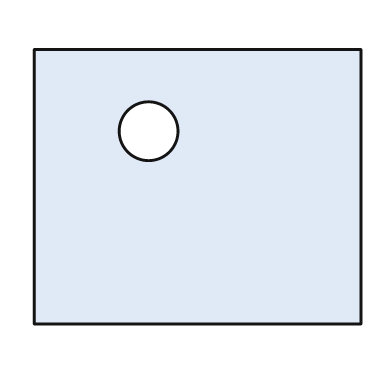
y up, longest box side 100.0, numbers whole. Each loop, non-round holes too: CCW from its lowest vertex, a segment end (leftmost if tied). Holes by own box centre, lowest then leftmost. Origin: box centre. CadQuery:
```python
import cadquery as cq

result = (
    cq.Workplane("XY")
    .moveTo(-50.0, -42.0)
    .lineTo(50.0, -42.0)
    .lineTo(50.0, 42.0)
    .lineTo(-50.0, 42.0)
    .close()
    .moveTo(-15.0, 17.0)
    .circle(9.0)
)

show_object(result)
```